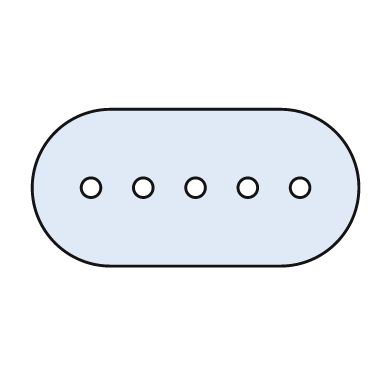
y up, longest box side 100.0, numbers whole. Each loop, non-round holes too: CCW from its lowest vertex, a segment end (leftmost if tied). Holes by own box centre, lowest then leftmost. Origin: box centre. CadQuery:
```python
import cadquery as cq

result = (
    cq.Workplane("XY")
    .moveTo(-26.0, -24.0)
    .lineTo(26.0, -24.0)
    .threePointArc((50.0, 0.0), (26.0, 24.0))
    .lineTo(-26.0, 24.0)
    .threePointArc((-50.0, 0.0), (-26.0, -24.0))
    .close()
    .moveTo(-32.0, 0.0)
    .circle(3.0)
    .moveTo(-16.0, 0.0)
    .circle(3.0)
    .moveTo(0.0, 0.0)
    .circle(3.0)
    .moveTo(16.0, 0.0)
    .circle(3.0)
    .moveTo(32.0, 0.0)
    .circle(3.0)
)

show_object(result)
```